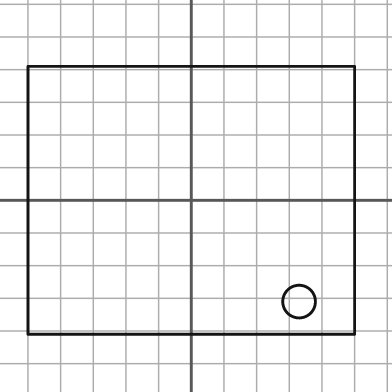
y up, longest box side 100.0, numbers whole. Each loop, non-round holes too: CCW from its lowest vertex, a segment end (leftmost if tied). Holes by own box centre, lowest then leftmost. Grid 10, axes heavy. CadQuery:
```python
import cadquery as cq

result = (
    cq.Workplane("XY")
    .moveTo(-50.0, -41.0)
    .lineTo(50.0, -41.0)
    .lineTo(50.0, 41.0)
    .lineTo(-50.0, 41.0)
    .close()
    .moveTo(33.0, -31.0)
    .circle(5.0)
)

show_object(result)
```